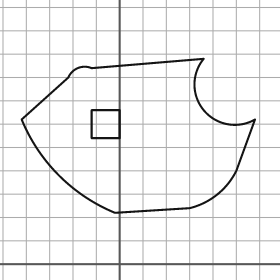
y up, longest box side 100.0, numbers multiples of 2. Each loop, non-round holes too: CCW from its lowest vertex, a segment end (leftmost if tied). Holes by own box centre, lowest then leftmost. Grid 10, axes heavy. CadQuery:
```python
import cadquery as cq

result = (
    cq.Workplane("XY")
    .moveTo(-2.0, 22.0)
    .lineTo(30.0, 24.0)
    .threePointArc((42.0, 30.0), (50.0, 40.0))
    .lineTo(58.0, 62.0)
    .threePointArc((36.0, 66.0), (36.0, 88.0))
    .lineTo(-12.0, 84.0)
    .threePointArc((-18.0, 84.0), (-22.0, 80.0))
    .lineTo(-42.0, 62.0)
    .threePointArc((-26.0, 38.0), (-2.0, 22.0))
    .close()
    .moveTo(-12.0, 54.0)
    .lineTo(0.0, 54.0)
    .lineTo(0.0, 66.0)
    .lineTo(-12.0, 66.0)
    .close()
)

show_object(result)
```